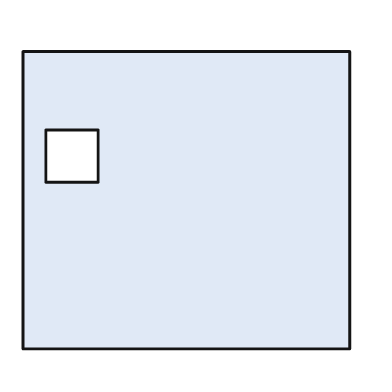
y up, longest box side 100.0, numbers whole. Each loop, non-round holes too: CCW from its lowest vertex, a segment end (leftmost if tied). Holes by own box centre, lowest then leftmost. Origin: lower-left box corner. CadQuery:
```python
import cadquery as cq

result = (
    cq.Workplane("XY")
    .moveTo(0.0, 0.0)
    .lineTo(100.0, 0.0)
    .lineTo(100.0, 91.0)
    .lineTo(0.0, 91.0)
    .close()
    .moveTo(7.0, 51.0)
    .lineTo(23.0, 51.0)
    .lineTo(23.0, 67.0)
    .lineTo(7.0, 67.0)
    .close()
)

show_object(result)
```